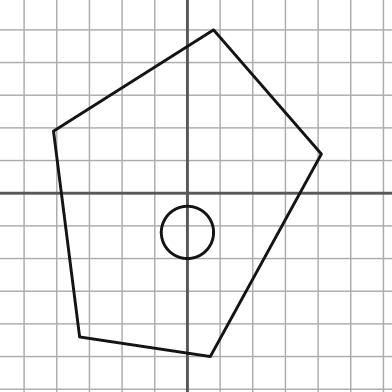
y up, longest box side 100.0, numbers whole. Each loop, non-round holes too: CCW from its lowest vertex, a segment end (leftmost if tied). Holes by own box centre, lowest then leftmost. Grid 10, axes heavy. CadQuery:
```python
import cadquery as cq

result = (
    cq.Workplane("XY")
    .moveTo(7.0, -50.0)
    .lineTo(41.0, 12.0)
    .lineTo(8.0, 50.0)
    .lineTo(-41.0, 19.0)
    .lineTo(-33.0, -44.0)
    .close()
    .moveTo(0.0, -12.0)
    .circle(8.0)
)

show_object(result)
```